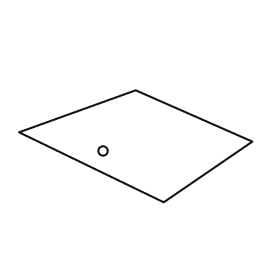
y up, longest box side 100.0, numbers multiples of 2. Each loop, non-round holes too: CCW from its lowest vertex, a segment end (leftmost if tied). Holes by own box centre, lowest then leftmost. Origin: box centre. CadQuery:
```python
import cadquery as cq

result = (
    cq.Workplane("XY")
    .moveTo(12.0, -24.0)
    .lineTo(50.0, 2.0)
    .lineTo(0.0, 24.0)
    .lineTo(-50.0, 6.0)
    .close()
    .moveTo(-14.0, -2.0)
    .circle(2.0)
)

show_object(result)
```